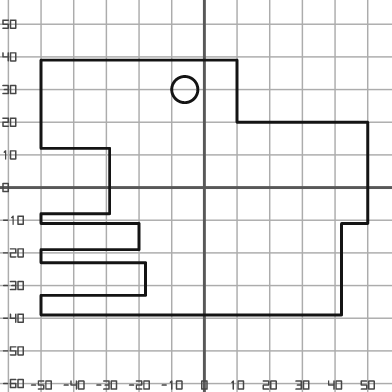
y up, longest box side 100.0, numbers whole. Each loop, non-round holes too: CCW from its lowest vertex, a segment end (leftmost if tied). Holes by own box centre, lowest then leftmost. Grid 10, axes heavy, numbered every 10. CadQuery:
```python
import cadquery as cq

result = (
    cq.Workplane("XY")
    .moveTo(-50.0, -39.0)
    .lineTo(42.0, -39.0)
    .lineTo(42.0, -11.0)
    .lineTo(50.0, -11.0)
    .lineTo(50.0, 20.0)
    .lineTo(10.0, 20.0)
    .lineTo(10.0, 39.0)
    .lineTo(-50.0, 39.0)
    .lineTo(-50.0, 12.0)
    .lineTo(-29.0, 12.0)
    .lineTo(-29.0, -8.0)
    .lineTo(-50.0, -8.0)
    .lineTo(-50.0, -11.0)
    .lineTo(-20.0, -11.0)
    .lineTo(-20.0, -19.0)
    .lineTo(-50.0, -19.0)
    .lineTo(-50.0, -23.0)
    .lineTo(-18.0, -23.0)
    .lineTo(-18.0, -33.0)
    .lineTo(-50.0, -33.0)
    .close()
    .moveTo(-6.0, 30.0)
    .circle(4.0)
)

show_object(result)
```